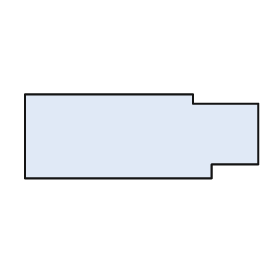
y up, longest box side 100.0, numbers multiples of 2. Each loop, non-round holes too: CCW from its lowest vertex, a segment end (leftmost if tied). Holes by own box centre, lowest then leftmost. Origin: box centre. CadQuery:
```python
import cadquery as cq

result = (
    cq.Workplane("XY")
    .moveTo(-50.0, -18.0)
    .lineTo(30.0, -18.0)
    .lineTo(30.0, -12.0)
    .lineTo(50.0, -12.0)
    .lineTo(50.0, 14.0)
    .lineTo(22.0, 14.0)
    .lineTo(22.0, 18.0)
    .lineTo(-50.0, 18.0)
    .close()
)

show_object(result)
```